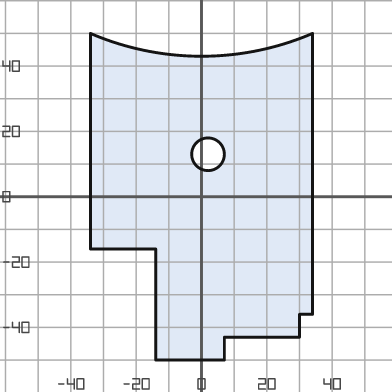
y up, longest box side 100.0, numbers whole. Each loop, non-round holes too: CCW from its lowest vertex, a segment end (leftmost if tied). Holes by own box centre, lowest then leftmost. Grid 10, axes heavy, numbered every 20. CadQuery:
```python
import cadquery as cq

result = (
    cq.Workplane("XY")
    .moveTo(-14.0, -50.0)
    .lineTo(7.0, -50.0)
    .lineTo(7.0, -43.0)
    .lineTo(30.0, -43.0)
    .lineTo(30.0, -36.0)
    .lineTo(34.0, -36.0)
    .lineTo(34.0, 50.0)
    .threePointArc((0.0, 43.0), (-34.0, 50.0))
    .lineTo(-34.0, -16.0)
    .lineTo(-14.0, -16.0)
    .close()
    .moveTo(2.0, 13.0)
    .circle(5.0)
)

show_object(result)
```